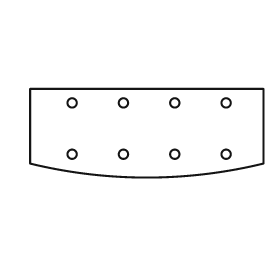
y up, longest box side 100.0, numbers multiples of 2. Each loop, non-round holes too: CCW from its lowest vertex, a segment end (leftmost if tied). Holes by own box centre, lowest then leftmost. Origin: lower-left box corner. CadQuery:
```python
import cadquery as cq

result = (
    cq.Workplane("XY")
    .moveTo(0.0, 6.0)
    .threePointArc((50.0, 0.0), (100.0, 6.0))
    .lineTo(100.0, 38.0)
    .lineTo(0.0, 38.0)
    .close()
    .moveTo(18.0, 10.0)
    .circle(2.0)
    .moveTo(40.0, 10.0)
    .circle(2.0)
    .moveTo(62.0, 10.0)
    .circle(2.0)
    .moveTo(84.0, 10.0)
    .circle(2.0)
    .moveTo(18.0, 32.0)
    .circle(2.0)
    .moveTo(40.0, 32.0)
    .circle(2.0)
    .moveTo(62.0, 32.0)
    .circle(2.0)
    .moveTo(84.0, 32.0)
    .circle(2.0)
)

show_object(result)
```